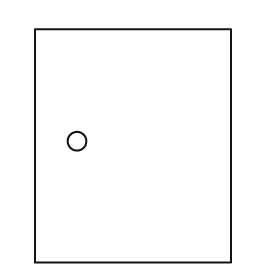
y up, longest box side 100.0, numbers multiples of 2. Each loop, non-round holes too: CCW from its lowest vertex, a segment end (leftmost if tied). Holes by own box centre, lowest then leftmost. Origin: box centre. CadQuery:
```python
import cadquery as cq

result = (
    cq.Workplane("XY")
    .moveTo(-42.0, -50.0)
    .lineTo(42.0, -50.0)
    .lineTo(42.0, 50.0)
    .lineTo(-42.0, 50.0)
    .close()
    .moveTo(-24.0, 2.0)
    .circle(4.0)
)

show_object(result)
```